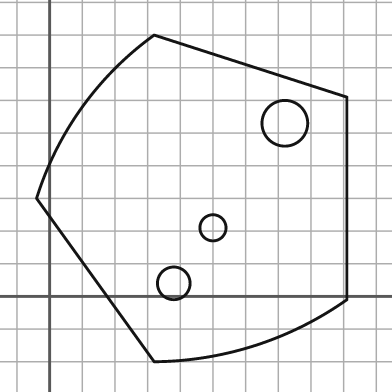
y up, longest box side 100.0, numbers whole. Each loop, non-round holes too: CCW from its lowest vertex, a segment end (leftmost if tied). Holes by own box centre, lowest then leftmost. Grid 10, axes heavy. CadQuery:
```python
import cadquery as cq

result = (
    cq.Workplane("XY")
    .moveTo(32.0, -20.0)
    .threePointArc((63.0, -15.0), (91.0, -1.0))
    .lineTo(91.0, 61.0)
    .lineTo(32.0, 80.0)
    .threePointArc((10.0, 58.0), (-4.0, 30.0))
    .close()
    .moveTo(38.0, 4.0)
    .circle(5.0)
    .moveTo(50.0, 21.0)
    .circle(4.0)
    .moveTo(72.0, 53.0)
    .circle(7.0)
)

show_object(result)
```